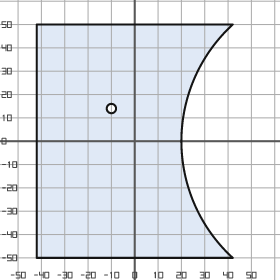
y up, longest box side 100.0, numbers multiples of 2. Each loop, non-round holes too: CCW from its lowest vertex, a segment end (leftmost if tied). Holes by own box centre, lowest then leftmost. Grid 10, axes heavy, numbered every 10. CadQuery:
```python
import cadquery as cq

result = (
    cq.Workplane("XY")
    .moveTo(-42.0, -50.0)
    .lineTo(42.0, -50.0)
    .threePointArc((20.0, 0.0), (42.0, 50.0))
    .lineTo(-42.0, 50.0)
    .close()
    .moveTo(-10.0, 14.0)
    .circle(2.0)
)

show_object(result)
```